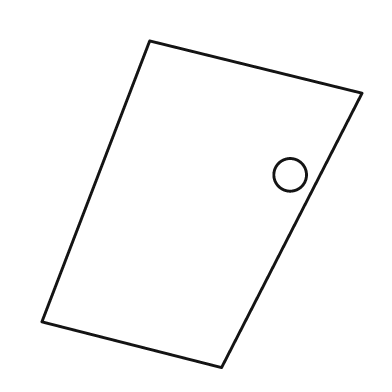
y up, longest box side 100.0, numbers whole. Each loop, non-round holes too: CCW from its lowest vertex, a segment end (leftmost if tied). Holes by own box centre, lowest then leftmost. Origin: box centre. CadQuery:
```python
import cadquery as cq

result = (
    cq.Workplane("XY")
    .moveTo(6.0, -50.0)
    .lineTo(49.0, 34.0)
    .lineTo(-16.0, 50.0)
    .lineTo(-49.0, -36.0)
    .close()
    .moveTo(27.0, 9.0)
    .circle(5.0)
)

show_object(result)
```